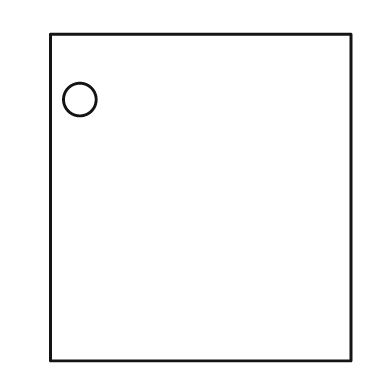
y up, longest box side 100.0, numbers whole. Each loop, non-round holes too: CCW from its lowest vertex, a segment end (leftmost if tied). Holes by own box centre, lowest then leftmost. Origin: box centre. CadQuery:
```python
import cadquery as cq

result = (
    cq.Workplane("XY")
    .moveTo(-46.0, -50.0)
    .lineTo(46.0, -50.0)
    .lineTo(46.0, 50.0)
    .lineTo(-46.0, 50.0)
    .close()
    .moveTo(-37.0, 30.0)
    .circle(5.0)
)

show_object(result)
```